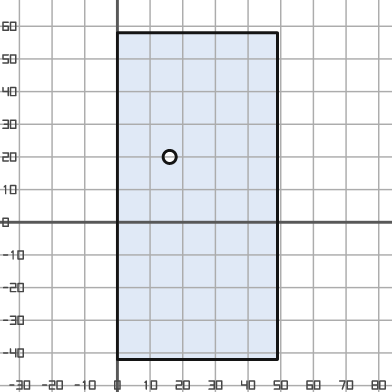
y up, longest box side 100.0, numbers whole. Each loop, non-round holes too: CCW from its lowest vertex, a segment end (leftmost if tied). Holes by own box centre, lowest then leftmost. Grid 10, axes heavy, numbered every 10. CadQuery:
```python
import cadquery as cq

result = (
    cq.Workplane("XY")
    .moveTo(0.0, -42.0)
    .lineTo(49.0, -42.0)
    .lineTo(49.0, 58.0)
    .lineTo(0.0, 58.0)
    .close()
    .moveTo(16.0, 20.0)
    .circle(2.0)
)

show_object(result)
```